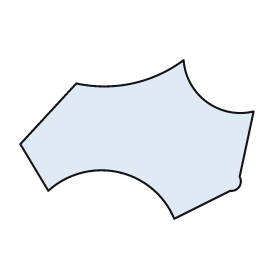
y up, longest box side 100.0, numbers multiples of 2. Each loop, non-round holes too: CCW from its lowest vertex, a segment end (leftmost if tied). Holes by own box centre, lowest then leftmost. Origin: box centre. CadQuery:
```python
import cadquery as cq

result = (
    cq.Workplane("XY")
    .moveTo(16.0, -34.0)
    .lineTo(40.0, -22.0)
    .threePointArc((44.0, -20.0), (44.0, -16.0))
    .lineTo(50.0, 12.0)
    .threePointArc((30.0, 16.0), (20.0, 34.0))
    .threePointArc((-2.0, 24.0), (-26.0, 24.0))
    .lineTo(-50.0, -2.0)
    .lineTo(-38.0, -22.0)
    .threePointArc((-8.0, -14.0), (16.0, -34.0))
    .close()
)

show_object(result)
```